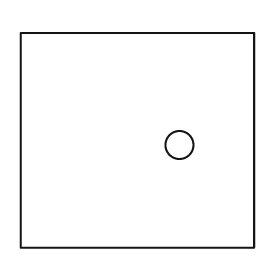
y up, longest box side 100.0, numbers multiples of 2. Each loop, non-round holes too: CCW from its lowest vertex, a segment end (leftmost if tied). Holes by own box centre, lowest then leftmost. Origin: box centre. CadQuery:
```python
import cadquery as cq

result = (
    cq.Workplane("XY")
    .moveTo(-50.0, -46.0)
    .lineTo(50.0, -46.0)
    .lineTo(50.0, 46.0)
    .lineTo(-50.0, 46.0)
    .close()
    .moveTo(18.0, -2.0)
    .circle(6.0)
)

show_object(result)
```